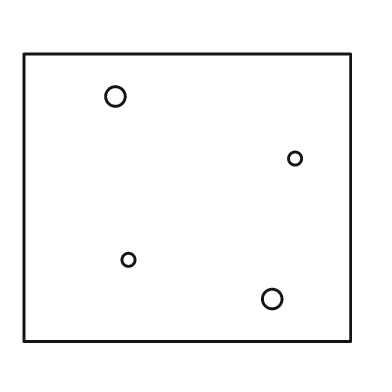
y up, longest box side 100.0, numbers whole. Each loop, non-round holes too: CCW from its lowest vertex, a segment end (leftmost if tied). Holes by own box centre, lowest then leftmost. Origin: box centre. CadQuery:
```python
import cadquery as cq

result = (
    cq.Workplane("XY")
    .moveTo(-50.0, -44.0)
    .lineTo(50.0, -44.0)
    .lineTo(50.0, 44.0)
    .lineTo(-50.0, 44.0)
    .close()
    .moveTo(26.0, -31.0)
    .circle(3.0)
    .moveTo(-18.0, -19.0)
    .circle(2.0)
    .moveTo(33.0, 12.0)
    .circle(2.0)
    .moveTo(-22.0, 31.0)
    .circle(3.0)
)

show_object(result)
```